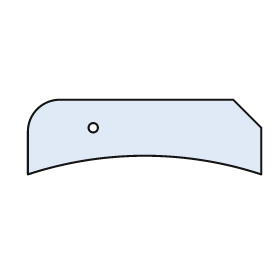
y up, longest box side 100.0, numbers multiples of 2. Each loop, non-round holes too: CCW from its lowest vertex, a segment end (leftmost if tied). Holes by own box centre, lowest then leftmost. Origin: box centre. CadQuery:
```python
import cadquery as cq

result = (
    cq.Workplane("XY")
    .moveTo(-50.0, -16.0)
    .threePointArc((0.0, -8.0), (50.0, -16.0))
    .lineTo(50.0, 4.0)
    .lineTo(38.0, 16.0)
    .lineTo(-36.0, 16.0)
    .threePointArc((-46.0, 12.0), (-50.0, 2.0))
    .close()
    .moveTo(-22.0, 4.0)
    .circle(2.0)
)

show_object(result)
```